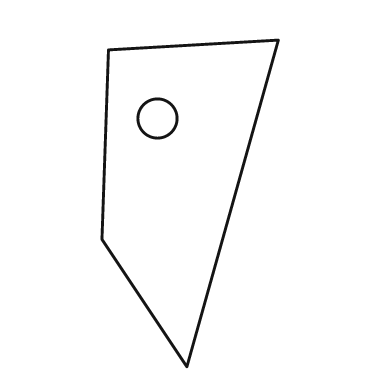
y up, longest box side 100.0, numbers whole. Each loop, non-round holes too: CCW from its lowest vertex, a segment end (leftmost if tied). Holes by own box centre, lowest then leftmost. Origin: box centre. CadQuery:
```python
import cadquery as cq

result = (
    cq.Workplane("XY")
    .moveTo(-1.0, -50.0)
    .lineTo(27.0, 50.0)
    .lineTo(-25.0, 47.0)
    .lineTo(-27.0, -11.0)
    .close()
    .moveTo(-10.0, 26.0)
    .circle(6.0)
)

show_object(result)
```